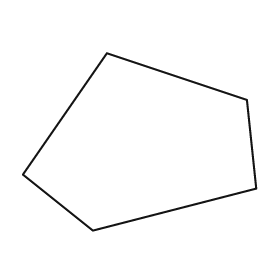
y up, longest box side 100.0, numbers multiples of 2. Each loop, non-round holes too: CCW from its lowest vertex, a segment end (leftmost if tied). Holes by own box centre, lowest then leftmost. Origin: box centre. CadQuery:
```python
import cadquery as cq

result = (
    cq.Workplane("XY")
    .moveTo(-20.0, -38.0)
    .lineTo(50.0, -20.0)
    .lineTo(46.0, 18.0)
    .lineTo(-14.0, 38.0)
    .lineTo(-50.0, -14.0)
    .close()
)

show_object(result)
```